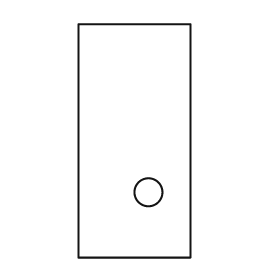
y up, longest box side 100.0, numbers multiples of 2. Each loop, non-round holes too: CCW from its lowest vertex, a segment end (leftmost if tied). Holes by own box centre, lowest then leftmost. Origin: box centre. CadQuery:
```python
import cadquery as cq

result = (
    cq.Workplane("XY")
    .moveTo(-24.0, -50.0)
    .lineTo(24.0, -50.0)
    .lineTo(24.0, 50.0)
    .lineTo(-24.0, 50.0)
    .close()
    .moveTo(6.0, -22.0)
    .circle(6.0)
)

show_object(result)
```